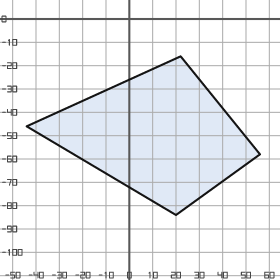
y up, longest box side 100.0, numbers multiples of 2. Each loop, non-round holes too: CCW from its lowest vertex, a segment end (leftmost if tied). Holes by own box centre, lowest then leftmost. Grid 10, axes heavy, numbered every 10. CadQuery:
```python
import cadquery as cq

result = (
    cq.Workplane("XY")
    .moveTo(20.0, -84.0)
    .lineTo(56.0, -58.0)
    .lineTo(22.0, -16.0)
    .lineTo(-44.0, -46.0)
    .close()
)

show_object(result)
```